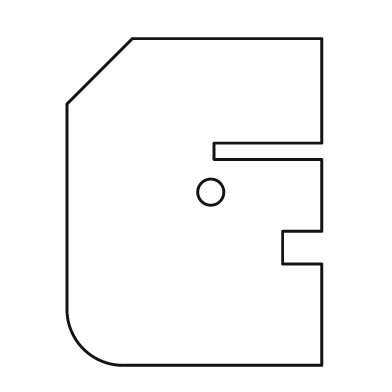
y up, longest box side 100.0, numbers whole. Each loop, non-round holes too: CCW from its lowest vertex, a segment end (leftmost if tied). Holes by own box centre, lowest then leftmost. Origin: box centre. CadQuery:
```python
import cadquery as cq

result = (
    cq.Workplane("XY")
    .moveTo(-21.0, -50.0)
    .lineTo(39.0, -50.0)
    .lineTo(39.0, -19.0)
    .lineTo(27.0, -19.0)
    .lineTo(27.0, -9.0)
    .lineTo(39.0, -9.0)
    .lineTo(39.0, 13.0)
    .lineTo(6.0, 13.0)
    .lineTo(6.0, 18.0)
    .lineTo(39.0, 18.0)
    .lineTo(39.0, 50.0)
    .lineTo(-19.0, 50.0)
    .lineTo(-39.0, 30.0)
    .lineTo(-39.0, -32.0)
    .threePointArc((-34.0, -45.0), (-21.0, -50.0))
    .close()
    .moveTo(5.0, 3.0)
    .circle(4.0)
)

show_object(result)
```